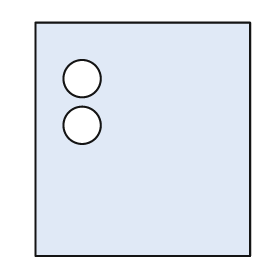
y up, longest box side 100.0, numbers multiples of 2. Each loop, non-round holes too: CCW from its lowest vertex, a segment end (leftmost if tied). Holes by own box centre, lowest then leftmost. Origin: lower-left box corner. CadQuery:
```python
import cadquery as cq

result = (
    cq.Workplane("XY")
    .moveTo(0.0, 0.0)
    .lineTo(92.0, 0.0)
    .lineTo(92.0, 100.0)
    .lineTo(0.0, 100.0)
    .close()
    .moveTo(20.0, 56.0)
    .circle(8.0)
    .moveTo(20.0, 76.0)
    .circle(8.0)
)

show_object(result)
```